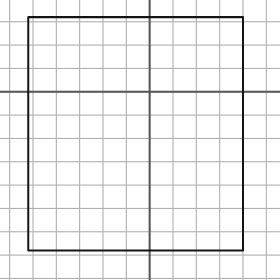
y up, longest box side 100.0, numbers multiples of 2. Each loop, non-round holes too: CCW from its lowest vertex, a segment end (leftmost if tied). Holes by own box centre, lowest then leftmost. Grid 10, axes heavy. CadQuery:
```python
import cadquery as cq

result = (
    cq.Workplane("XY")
    .moveTo(-52.0, -68.0)
    .lineTo(40.0, -68.0)
    .lineTo(40.0, 32.0)
    .lineTo(-52.0, 32.0)
    .close()
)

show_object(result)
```